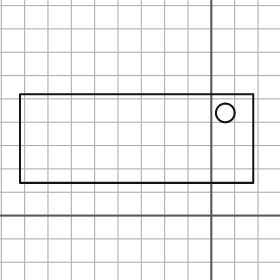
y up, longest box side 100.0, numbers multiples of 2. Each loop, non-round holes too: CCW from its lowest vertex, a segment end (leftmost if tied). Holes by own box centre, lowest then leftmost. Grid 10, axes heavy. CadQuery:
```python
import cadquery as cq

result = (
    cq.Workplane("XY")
    .moveTo(-82.0, 14.0)
    .lineTo(18.0, 14.0)
    .lineTo(18.0, 52.0)
    .lineTo(-82.0, 52.0)
    .close()
    .moveTo(6.0, 44.0)
    .circle(4.0)
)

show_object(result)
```